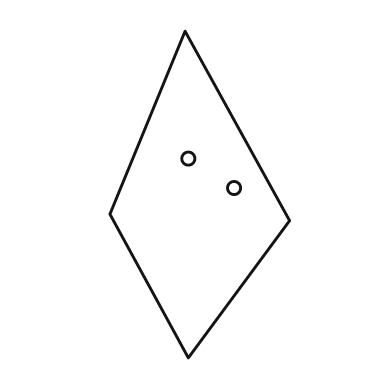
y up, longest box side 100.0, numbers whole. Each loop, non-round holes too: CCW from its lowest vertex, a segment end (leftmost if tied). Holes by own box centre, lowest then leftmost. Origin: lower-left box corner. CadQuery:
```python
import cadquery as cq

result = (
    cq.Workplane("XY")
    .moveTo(24.0, 0.0)
    .lineTo(55.0, 42.0)
    .lineTo(23.0, 100.0)
    .lineTo(0.0, 44.0)
    .close()
    .moveTo(38.0, 52.0)
    .circle(2.0)
    .moveTo(24.0, 61.0)
    .circle(2.0)
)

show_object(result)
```